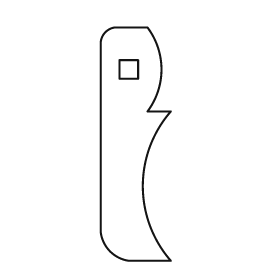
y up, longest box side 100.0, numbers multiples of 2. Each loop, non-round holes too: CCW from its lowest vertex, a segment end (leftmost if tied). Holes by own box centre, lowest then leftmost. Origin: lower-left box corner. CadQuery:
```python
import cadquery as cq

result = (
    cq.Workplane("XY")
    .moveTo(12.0, 0.0)
    .lineTo(30.0, 0.0)
    .threePointArc((18.0, 32.0), (30.0, 64.0))
    .lineTo(20.0, 64.0)
    .threePointArc((26.0, 82.0), (20.0, 100.0))
    .lineTo(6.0, 100.0)
    .threePointArc((2.0, 98.0), (0.0, 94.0))
    .lineTo(0.0, 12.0)
    .threePointArc((4.0, 4.0), (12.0, 0.0))
    .close()
    .moveTo(8.0, 78.0)
    .lineTo(16.0, 78.0)
    .lineTo(16.0, 86.0)
    .lineTo(8.0, 86.0)
    .close()
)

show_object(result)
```